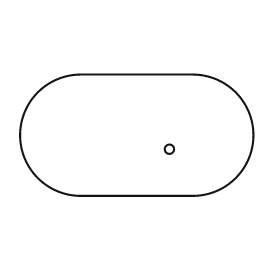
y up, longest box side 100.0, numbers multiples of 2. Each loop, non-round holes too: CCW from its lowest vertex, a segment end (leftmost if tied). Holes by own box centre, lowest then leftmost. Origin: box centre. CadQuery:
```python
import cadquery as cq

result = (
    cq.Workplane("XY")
    .moveTo(-24.0, -26.0)
    .lineTo(24.0, -26.0)
    .threePointArc((50.0, 0.0), (24.0, 26.0))
    .lineTo(-24.0, 26.0)
    .threePointArc((-50.0, 0.0), (-24.0, -26.0))
    .close()
    .moveTo(14.0, -6.0)
    .circle(2.0)
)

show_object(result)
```